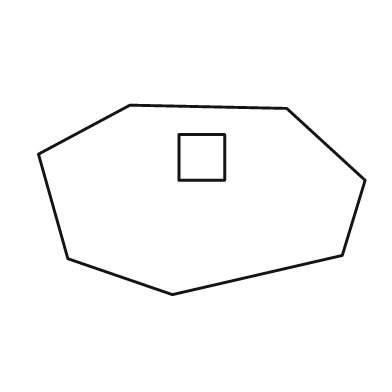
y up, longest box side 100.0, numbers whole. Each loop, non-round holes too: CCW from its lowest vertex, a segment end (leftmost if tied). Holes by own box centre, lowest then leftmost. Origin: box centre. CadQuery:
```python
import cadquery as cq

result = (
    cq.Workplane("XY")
    .moveTo(-9.0, -29.0)
    .lineTo(43.0, -17.0)
    .lineTo(50.0, 6.0)
    .lineTo(26.0, 28.0)
    .lineTo(-22.0, 29.0)
    .lineTo(-50.0, 14.0)
    .lineTo(-41.0, -18.0)
    .close()
    .moveTo(-7.0, 6.0)
    .lineTo(7.0, 6.0)
    .lineTo(7.0, 20.0)
    .lineTo(-7.0, 20.0)
    .close()
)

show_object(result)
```